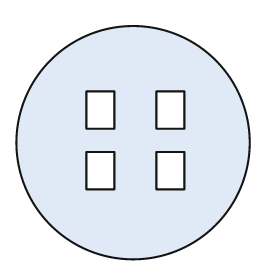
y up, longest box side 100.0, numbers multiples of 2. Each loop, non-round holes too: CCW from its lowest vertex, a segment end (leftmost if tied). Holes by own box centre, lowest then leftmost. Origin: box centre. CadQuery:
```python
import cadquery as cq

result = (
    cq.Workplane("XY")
    .moveTo(0.0, 0.0)
    .circle(50.0)
    .moveTo(-20.0, -20.0)
    .lineTo(-8.0, -20.0)
    .lineTo(-8.0, -4.0)
    .lineTo(-20.0, -4.0)
    .close()
    .moveTo(10.0, -20.0)
    .lineTo(22.0, -20.0)
    .lineTo(22.0, -4.0)
    .lineTo(10.0, -4.0)
    .close()
    .moveTo(-20.0, 6.0)
    .lineTo(-8.0, 6.0)
    .lineTo(-8.0, 22.0)
    .lineTo(-20.0, 22.0)
    .close()
    .moveTo(10.0, 6.0)
    .lineTo(22.0, 6.0)
    .lineTo(22.0, 22.0)
    .lineTo(10.0, 22.0)
    .close()
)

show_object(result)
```